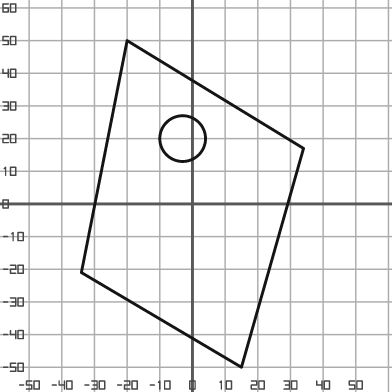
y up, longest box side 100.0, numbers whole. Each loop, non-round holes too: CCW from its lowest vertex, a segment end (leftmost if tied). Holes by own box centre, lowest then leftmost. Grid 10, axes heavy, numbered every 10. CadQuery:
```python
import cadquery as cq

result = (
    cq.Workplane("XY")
    .moveTo(15.0, -50.0)
    .lineTo(34.0, 17.0)
    .lineTo(-20.0, 50.0)
    .lineTo(-34.0, -21.0)
    .close()
    .moveTo(-3.0, 20.0)
    .circle(7.0)
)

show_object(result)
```